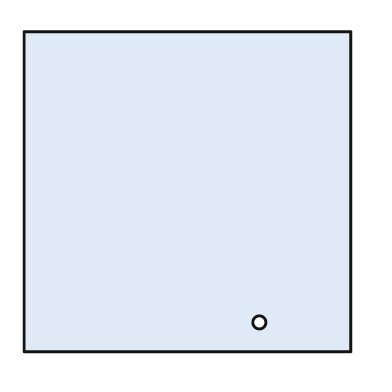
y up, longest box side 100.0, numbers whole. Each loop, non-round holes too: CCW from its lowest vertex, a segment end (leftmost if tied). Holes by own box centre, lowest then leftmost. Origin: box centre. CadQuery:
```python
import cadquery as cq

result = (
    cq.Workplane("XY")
    .moveTo(-50.0, -49.0)
    .lineTo(50.0, -49.0)
    .lineTo(50.0, 49.0)
    .lineTo(-50.0, 49.0)
    .close()
    .moveTo(22.0, -40.0)
    .circle(2.0)
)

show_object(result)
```